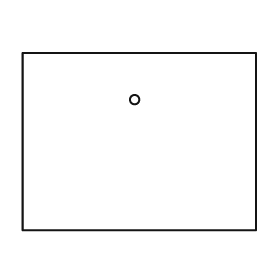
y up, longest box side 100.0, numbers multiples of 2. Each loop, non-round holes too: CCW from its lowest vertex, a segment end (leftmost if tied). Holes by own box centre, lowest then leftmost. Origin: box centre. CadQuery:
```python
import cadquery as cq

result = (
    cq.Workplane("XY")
    .moveTo(-50.0, -38.0)
    .lineTo(50.0, -38.0)
    .lineTo(50.0, 38.0)
    .lineTo(-50.0, 38.0)
    .close()
    .moveTo(-2.0, 18.0)
    .circle(2.0)
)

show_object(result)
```